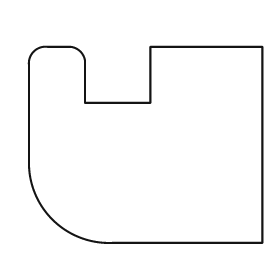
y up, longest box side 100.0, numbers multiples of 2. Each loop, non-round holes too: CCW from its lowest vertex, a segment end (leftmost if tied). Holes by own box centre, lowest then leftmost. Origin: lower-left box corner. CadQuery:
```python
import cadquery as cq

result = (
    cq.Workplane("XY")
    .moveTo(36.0, 0.0)
    .lineTo(100.0, 0.0)
    .lineTo(100.0, 84.0)
    .lineTo(52.0, 84.0)
    .lineTo(52.0, 60.0)
    .lineTo(24.0, 60.0)
    .lineTo(24.0, 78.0)
    .threePointArc((22.0, 82.0), (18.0, 84.0))
    .lineTo(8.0, 84.0)
    .threePointArc((2.0, 82.0), (0.0, 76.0))
    .lineTo(0.0, 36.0)
    .threePointArc((10.0, 10.0), (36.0, 0.0))
    .close()
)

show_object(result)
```